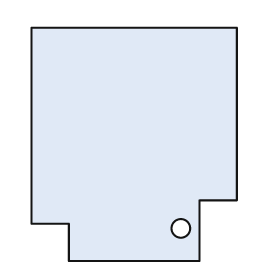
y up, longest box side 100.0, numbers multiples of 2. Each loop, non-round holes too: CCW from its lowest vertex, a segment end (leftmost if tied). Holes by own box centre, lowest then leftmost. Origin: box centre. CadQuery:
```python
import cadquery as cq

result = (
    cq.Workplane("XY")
    .moveTo(-28.0, -50.0)
    .lineTo(28.0, -50.0)
    .lineTo(28.0, -24.0)
    .lineTo(44.0, -24.0)
    .lineTo(44.0, 50.0)
    .lineTo(-44.0, 50.0)
    .lineTo(-44.0, -34.0)
    .lineTo(-28.0, -34.0)
    .close()
    .moveTo(20.0, -36.0)
    .circle(4.0)
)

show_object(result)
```